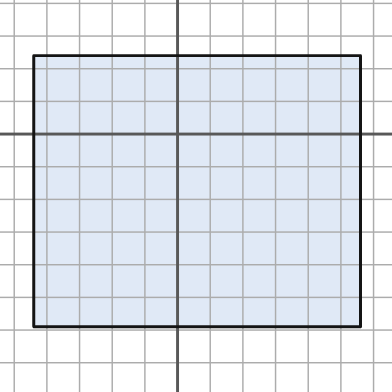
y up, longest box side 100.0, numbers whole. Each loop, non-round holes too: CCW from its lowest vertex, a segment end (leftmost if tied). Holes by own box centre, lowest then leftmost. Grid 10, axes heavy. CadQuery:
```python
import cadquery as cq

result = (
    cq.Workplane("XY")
    .moveTo(-44.0, -59.0)
    .lineTo(56.0, -59.0)
    .lineTo(56.0, 24.0)
    .lineTo(-44.0, 24.0)
    .close()
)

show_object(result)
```